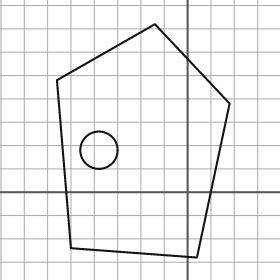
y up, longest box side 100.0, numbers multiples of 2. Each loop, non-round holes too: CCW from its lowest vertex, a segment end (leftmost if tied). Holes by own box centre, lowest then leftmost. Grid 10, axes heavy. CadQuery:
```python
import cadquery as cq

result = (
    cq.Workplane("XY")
    .moveTo(4.0, -28.0)
    .lineTo(18.0, 38.0)
    .lineTo(-14.0, 72.0)
    .lineTo(-56.0, 48.0)
    .lineTo(-50.0, -24.0)
    .close()
    .moveTo(-38.0, 18.0)
    .circle(8.0)
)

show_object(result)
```